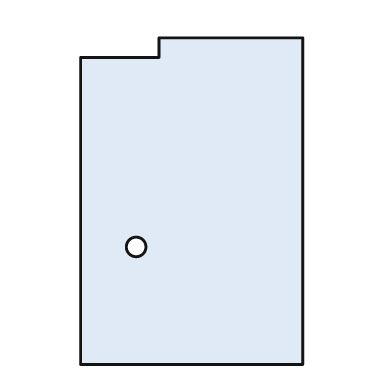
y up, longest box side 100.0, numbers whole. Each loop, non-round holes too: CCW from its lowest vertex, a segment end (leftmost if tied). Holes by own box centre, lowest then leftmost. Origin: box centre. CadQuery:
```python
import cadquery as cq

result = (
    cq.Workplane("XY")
    .moveTo(-34.0, -50.0)
    .lineTo(34.0, -50.0)
    .lineTo(34.0, 50.0)
    .lineTo(-10.0, 50.0)
    .lineTo(-10.0, 44.0)
    .lineTo(-34.0, 44.0)
    .close()
    .moveTo(-17.0, -14.0)
    .circle(3.0)
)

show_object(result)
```